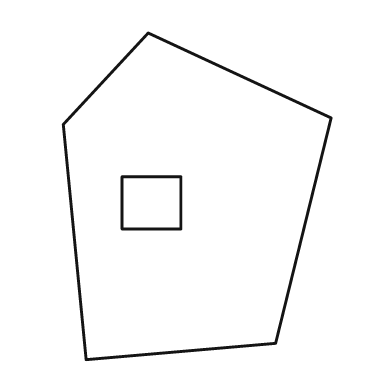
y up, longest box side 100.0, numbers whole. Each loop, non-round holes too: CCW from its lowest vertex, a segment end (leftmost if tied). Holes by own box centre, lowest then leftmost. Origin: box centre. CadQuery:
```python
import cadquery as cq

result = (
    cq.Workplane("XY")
    .moveTo(-34.0, -50.0)
    .lineTo(24.0, -45.0)
    .lineTo(41.0, 24.0)
    .lineTo(-15.0, 50.0)
    .lineTo(-41.0, 22.0)
    .close()
    .moveTo(-23.0, -10.0)
    .lineTo(-5.0, -10.0)
    .lineTo(-5.0, 6.0)
    .lineTo(-23.0, 6.0)
    .close()
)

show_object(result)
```